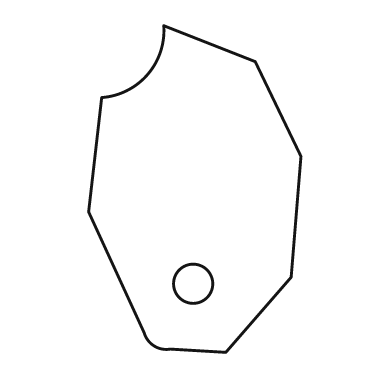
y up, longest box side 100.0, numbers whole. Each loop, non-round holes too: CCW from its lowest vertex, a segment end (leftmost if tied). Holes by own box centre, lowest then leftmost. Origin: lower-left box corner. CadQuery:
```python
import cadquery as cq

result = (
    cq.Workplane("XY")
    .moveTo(42.0, 0.0)
    .lineTo(62.0, 23.0)
    .lineTo(65.0, 60.0)
    .lineTo(51.0, 89.0)
    .lineTo(23.0, 100.0)
    .threePointArc((18.0, 85.0), (4.0, 78.0))
    .lineTo(0.0, 43.0)
    .lineTo(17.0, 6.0)
    .threePointArc((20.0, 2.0), (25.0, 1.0))
    .close()
    .moveTo(32.0, 21.0)
    .circle(6.0)
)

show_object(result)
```